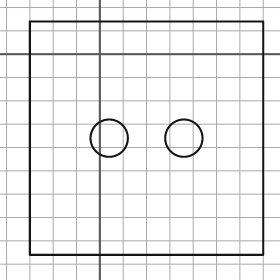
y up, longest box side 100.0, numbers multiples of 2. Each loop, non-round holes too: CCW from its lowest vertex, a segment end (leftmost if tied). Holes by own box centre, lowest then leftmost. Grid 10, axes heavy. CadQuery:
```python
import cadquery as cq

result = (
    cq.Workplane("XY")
    .moveTo(-30.0, -86.0)
    .lineTo(70.0, -86.0)
    .lineTo(70.0, 14.0)
    .lineTo(-30.0, 14.0)
    .close()
    .moveTo(4.0, -36.0)
    .circle(8.0)
    .moveTo(36.0, -36.0)
    .circle(8.0)
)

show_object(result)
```